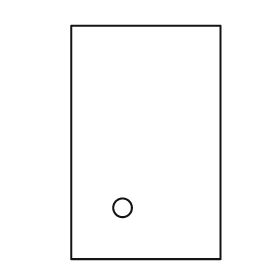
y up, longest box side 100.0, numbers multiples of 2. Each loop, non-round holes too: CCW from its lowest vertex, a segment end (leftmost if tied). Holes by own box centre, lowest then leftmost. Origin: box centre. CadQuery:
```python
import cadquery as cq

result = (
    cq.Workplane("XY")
    .moveTo(-32.0, -50.0)
    .lineTo(32.0, -50.0)
    .lineTo(32.0, 50.0)
    .lineTo(-32.0, 50.0)
    .close()
    .moveTo(-10.0, -28.0)
    .circle(4.0)
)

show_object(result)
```